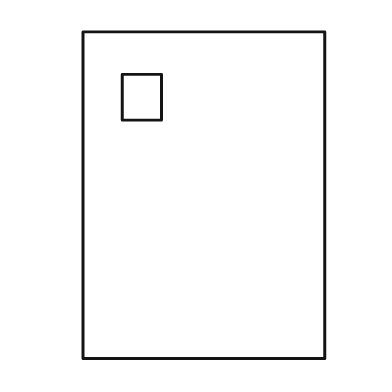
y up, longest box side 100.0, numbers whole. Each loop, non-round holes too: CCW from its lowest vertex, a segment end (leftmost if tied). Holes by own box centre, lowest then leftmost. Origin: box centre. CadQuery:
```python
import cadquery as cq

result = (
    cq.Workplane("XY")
    .moveTo(-37.0, -50.0)
    .lineTo(37.0, -50.0)
    .lineTo(37.0, 50.0)
    .lineTo(-37.0, 50.0)
    .close()
    .moveTo(-25.0, 23.0)
    .lineTo(-13.0, 23.0)
    .lineTo(-13.0, 37.0)
    .lineTo(-25.0, 37.0)
    .close()
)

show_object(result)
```